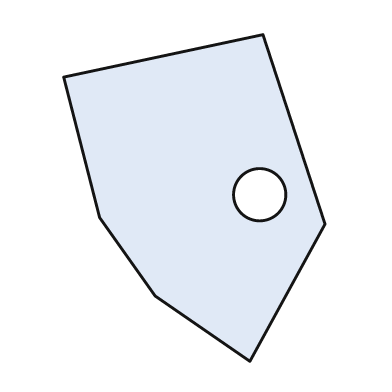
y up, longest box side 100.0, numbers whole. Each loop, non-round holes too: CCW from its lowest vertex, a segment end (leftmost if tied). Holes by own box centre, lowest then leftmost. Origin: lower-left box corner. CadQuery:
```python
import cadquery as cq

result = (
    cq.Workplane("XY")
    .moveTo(57.0, 0.0)
    .lineTo(80.0, 42.0)
    .lineTo(61.0, 100.0)
    .lineTo(0.0, 87.0)
    .lineTo(11.0, 44.0)
    .lineTo(28.0, 20.0)
    .close()
    .moveTo(60.0, 51.0)
    .circle(8.0)
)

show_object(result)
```